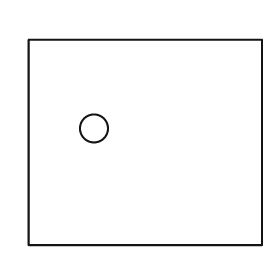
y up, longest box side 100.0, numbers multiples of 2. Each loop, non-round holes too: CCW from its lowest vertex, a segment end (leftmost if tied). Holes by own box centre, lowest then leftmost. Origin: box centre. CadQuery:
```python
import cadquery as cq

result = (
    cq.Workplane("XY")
    .moveTo(-50.0, -44.0)
    .lineTo(50.0, -44.0)
    .lineTo(50.0, 44.0)
    .lineTo(-50.0, 44.0)
    .close()
    .moveTo(-22.0, 6.0)
    .circle(6.0)
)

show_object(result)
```